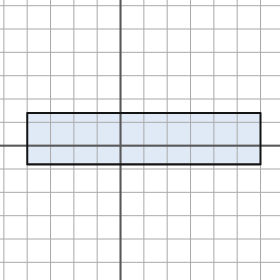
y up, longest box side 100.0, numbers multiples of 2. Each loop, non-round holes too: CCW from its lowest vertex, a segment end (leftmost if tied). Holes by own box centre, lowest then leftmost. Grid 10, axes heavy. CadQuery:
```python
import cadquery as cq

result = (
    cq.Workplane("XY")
    .moveTo(-40.0, -8.0)
    .lineTo(60.0, -8.0)
    .lineTo(60.0, 14.0)
    .lineTo(-40.0, 14.0)
    .close()
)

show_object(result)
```